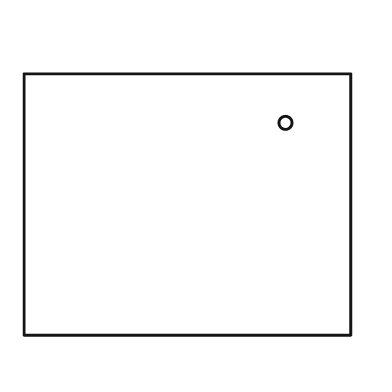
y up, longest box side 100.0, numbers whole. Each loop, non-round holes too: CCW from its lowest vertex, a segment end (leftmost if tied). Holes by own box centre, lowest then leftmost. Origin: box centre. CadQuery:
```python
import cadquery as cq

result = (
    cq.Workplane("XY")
    .moveTo(-50.0, -40.0)
    .lineTo(50.0, -40.0)
    .lineTo(50.0, 40.0)
    .lineTo(-50.0, 40.0)
    .close()
    .moveTo(30.0, 25.0)
    .circle(2.0)
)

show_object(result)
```